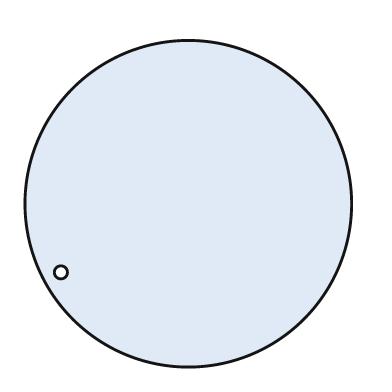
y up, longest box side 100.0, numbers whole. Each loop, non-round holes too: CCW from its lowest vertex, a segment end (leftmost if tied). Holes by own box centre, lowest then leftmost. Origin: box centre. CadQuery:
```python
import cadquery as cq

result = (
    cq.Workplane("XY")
    .moveTo(0.0, 0.0)
    .circle(50.0)
    .moveTo(-39.0, -21.0)
    .circle(2.0)
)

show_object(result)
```